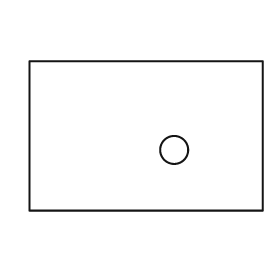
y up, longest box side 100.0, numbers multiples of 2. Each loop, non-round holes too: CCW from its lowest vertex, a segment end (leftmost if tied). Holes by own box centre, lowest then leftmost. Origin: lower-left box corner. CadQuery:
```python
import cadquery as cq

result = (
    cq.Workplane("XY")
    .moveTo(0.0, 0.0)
    .lineTo(100.0, 0.0)
    .lineTo(100.0, 64.0)
    .lineTo(0.0, 64.0)
    .close()
    .moveTo(62.0, 26.0)
    .circle(6.0)
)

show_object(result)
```